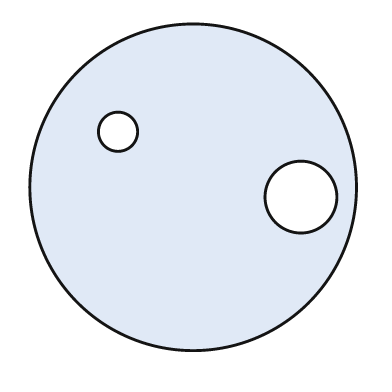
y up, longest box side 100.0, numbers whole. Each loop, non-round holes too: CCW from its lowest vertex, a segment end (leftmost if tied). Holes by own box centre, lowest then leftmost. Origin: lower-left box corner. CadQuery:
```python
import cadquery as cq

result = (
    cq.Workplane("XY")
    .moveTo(50.0, 50.0)
    .circle(50.0)
    .moveTo(83.0, 47.0)
    .circle(11.0)
    .moveTo(27.0, 67.0)
    .circle(6.0)
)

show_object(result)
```